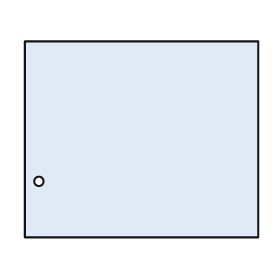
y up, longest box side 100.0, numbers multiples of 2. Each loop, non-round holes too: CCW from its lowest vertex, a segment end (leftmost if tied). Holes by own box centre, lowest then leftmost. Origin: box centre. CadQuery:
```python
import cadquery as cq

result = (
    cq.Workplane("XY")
    .moveTo(-50.0, -42.0)
    .lineTo(50.0, -42.0)
    .lineTo(50.0, 42.0)
    .lineTo(-50.0, 42.0)
    .close()
    .moveTo(-44.0, -18.0)
    .circle(2.0)
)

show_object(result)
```